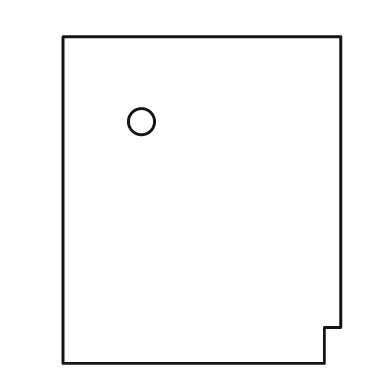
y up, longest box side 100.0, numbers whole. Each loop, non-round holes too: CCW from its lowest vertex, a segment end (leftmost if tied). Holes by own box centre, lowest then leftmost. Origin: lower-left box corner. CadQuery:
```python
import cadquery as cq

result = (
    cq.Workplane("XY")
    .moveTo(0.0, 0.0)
    .lineTo(80.0, 0.0)
    .lineTo(80.0, 11.0)
    .lineTo(85.0, 11.0)
    .lineTo(85.0, 100.0)
    .lineTo(0.0, 100.0)
    .close()
    .moveTo(24.0, 74.0)
    .circle(4.0)
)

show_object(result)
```